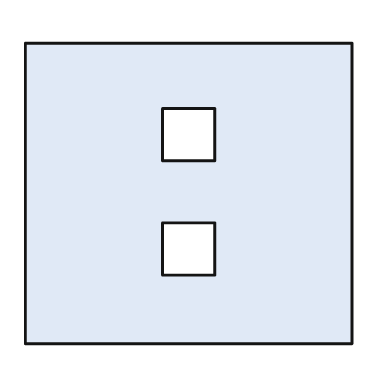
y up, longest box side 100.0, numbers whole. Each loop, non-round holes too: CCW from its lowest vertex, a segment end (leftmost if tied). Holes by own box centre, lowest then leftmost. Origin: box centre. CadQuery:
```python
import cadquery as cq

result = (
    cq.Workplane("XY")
    .moveTo(-50.0, -46.0)
    .lineTo(50.0, -46.0)
    .lineTo(50.0, 46.0)
    .lineTo(-50.0, 46.0)
    .close()
    .moveTo(-8.0, -25.0)
    .lineTo(8.0, -25.0)
    .lineTo(8.0, -9.0)
    .lineTo(-8.0, -9.0)
    .close()
    .moveTo(-8.0, 10.0)
    .lineTo(8.0, 10.0)
    .lineTo(8.0, 26.0)
    .lineTo(-8.0, 26.0)
    .close()
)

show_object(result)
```